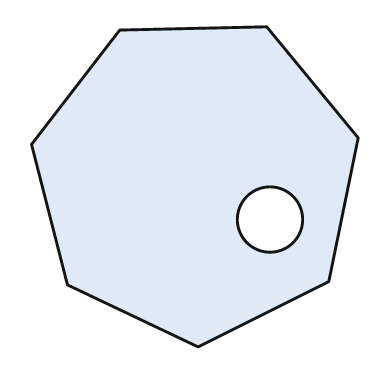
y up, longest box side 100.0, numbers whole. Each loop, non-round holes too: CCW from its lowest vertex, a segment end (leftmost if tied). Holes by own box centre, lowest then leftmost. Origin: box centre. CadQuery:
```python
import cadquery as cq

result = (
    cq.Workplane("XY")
    .moveTo(1.0, -49.0)
    .lineTo(41.0, -29.0)
    .lineTo(50.0, 15.0)
    .lineTo(22.0, 49.0)
    .lineTo(-23.0, 48.0)
    .lineTo(-50.0, 13.0)
    .lineTo(-39.0, -30.0)
    .close()
    .moveTo(23.0, -10.0)
    .circle(10.0)
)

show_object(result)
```